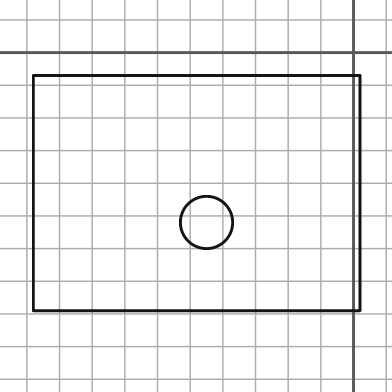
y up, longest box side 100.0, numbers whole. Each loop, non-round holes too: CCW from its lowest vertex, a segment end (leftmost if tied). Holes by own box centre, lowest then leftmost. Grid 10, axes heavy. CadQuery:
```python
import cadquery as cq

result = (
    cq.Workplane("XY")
    .moveTo(-98.0, -79.0)
    .lineTo(2.0, -79.0)
    .lineTo(2.0, -7.0)
    .lineTo(-98.0, -7.0)
    .close()
    .moveTo(-45.0, -52.0)
    .circle(8.0)
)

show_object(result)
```